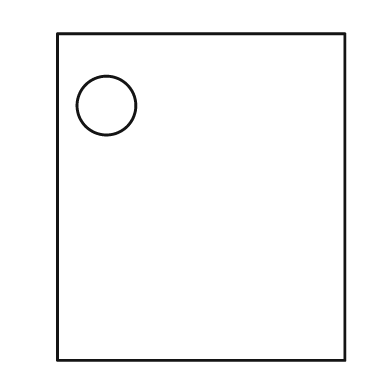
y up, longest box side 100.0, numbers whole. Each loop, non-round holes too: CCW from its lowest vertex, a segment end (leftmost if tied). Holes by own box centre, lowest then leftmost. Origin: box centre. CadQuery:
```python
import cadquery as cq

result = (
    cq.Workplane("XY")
    .moveTo(-44.0, -50.0)
    .lineTo(44.0, -50.0)
    .lineTo(44.0, 50.0)
    .lineTo(-44.0, 50.0)
    .close()
    .moveTo(-29.0, 28.0)
    .circle(9.0)
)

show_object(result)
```